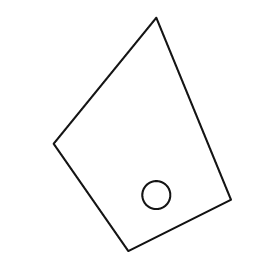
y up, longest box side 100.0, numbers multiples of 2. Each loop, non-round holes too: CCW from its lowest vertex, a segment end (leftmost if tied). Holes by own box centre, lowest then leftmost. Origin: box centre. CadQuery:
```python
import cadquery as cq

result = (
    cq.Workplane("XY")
    .moveTo(-6.0, -50.0)
    .lineTo(38.0, -28.0)
    .lineTo(6.0, 50.0)
    .lineTo(-38.0, -4.0)
    .close()
    .moveTo(6.0, -26.0)
    .circle(6.0)
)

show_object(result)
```